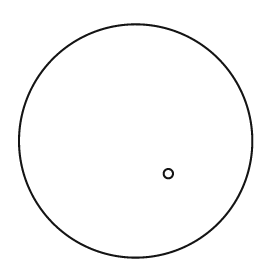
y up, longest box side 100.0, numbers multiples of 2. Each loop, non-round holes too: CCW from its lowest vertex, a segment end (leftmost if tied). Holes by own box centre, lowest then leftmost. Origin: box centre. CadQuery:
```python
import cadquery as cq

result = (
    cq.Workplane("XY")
    .moveTo(0.0, 0.0)
    .circle(50.0)
    .moveTo(14.0, -14.0)
    .circle(2.0)
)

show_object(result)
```